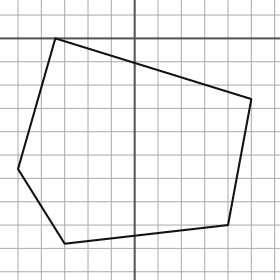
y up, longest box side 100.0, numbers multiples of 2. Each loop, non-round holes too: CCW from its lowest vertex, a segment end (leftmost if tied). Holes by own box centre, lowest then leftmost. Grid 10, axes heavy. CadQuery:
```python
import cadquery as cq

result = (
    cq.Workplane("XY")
    .moveTo(-30.0, -88.0)
    .lineTo(40.0, -80.0)
    .lineTo(50.0, -26.0)
    .lineTo(-34.0, 0.0)
    .lineTo(-50.0, -56.0)
    .close()
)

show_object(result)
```